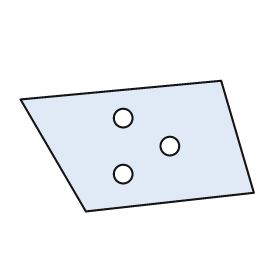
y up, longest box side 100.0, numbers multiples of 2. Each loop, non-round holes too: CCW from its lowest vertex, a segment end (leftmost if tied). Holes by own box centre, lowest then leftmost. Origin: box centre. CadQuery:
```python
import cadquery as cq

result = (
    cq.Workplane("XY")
    .moveTo(-22.0, -28.0)
    .lineTo(50.0, -20.0)
    .lineTo(36.0, 28.0)
    .lineTo(-50.0, 20.0)
    .close()
    .moveTo(-6.0, -12.0)
    .circle(4.0)
    .moveTo(14.0, 0.0)
    .circle(4.0)
    .moveTo(-6.0, 12.0)
    .circle(4.0)
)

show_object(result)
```